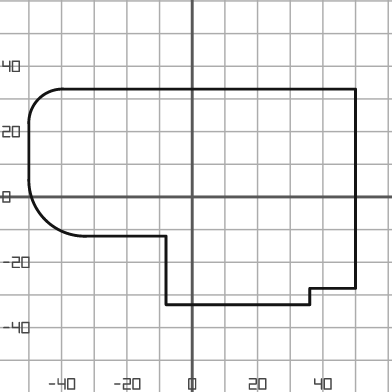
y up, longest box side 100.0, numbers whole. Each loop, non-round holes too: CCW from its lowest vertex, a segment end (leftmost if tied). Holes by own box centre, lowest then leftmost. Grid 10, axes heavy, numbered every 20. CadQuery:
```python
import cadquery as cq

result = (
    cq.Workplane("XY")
    .moveTo(-8.0, -33.0)
    .lineTo(36.0, -33.0)
    .lineTo(36.0, -28.0)
    .lineTo(50.0, -28.0)
    .lineTo(50.0, 33.0)
    .lineTo(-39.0, 33.0)
    .threePointArc((-47.0, 30.0), (-50.0, 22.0))
    .lineTo(-50.0, 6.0)
    .threePointArc((-45.0, -7.0), (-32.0, -12.0))
    .lineTo(-8.0, -12.0)
    .close()
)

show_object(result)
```